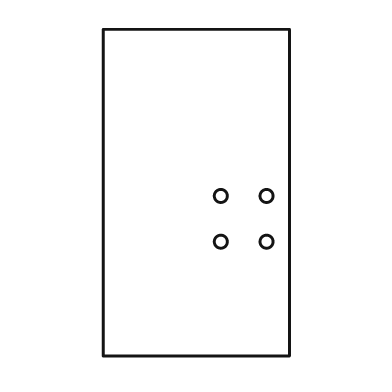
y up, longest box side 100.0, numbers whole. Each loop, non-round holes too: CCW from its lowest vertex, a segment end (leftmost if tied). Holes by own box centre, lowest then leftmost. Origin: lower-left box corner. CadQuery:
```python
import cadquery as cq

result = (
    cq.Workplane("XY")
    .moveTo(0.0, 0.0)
    .lineTo(57.0, 0.0)
    .lineTo(57.0, 100.0)
    .lineTo(0.0, 100.0)
    .close()
    .moveTo(36.0, 35.0)
    .circle(2.0)
    .moveTo(50.0, 35.0)
    .circle(2.0)
    .moveTo(36.0, 49.0)
    .circle(2.0)
    .moveTo(50.0, 49.0)
    .circle(2.0)
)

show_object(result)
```